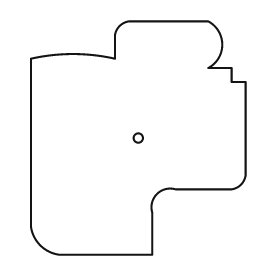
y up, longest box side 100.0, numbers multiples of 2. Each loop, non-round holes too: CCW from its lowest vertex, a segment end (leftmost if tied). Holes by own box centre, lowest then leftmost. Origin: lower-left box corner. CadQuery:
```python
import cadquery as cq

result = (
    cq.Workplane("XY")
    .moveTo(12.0, 0.0)
    .lineTo(52.0, 0.0)
    .lineTo(52.0, 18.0)
    .threePointArc((54.0, 26.0), (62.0, 28.0))
    .lineTo(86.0, 28.0)
    .threePointArc((90.0, 30.0), (92.0, 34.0))
    .lineTo(92.0, 74.0)
    .lineTo(86.0, 74.0)
    .lineTo(86.0, 80.0)
    .lineTo(76.0, 80.0)
    .threePointArc((82.0, 90.0), (76.0, 100.0))
    .lineTo(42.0, 100.0)
    .threePointArc((38.0, 98.0), (36.0, 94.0))
    .lineTo(36.0, 84.0)
    .threePointArc((18.0, 86.0), (0.0, 84.0))
    .lineTo(0.0, 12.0)
    .threePointArc((4.0, 4.0), (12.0, 0.0))
    .close()
    .moveTo(46.0, 50.0)
    .circle(2.0)
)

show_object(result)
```